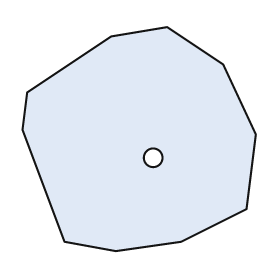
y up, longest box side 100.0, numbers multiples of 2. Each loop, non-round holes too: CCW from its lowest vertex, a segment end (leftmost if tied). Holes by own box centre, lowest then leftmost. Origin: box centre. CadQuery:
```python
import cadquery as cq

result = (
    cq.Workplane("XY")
    .moveTo(-10.0, -48.0)
    .lineTo(18.0, -44.0)
    .lineTo(46.0, -30.0)
    .lineTo(50.0, 2.0)
    .lineTo(36.0, 32.0)
    .lineTo(12.0, 48.0)
    .lineTo(-12.0, 44.0)
    .lineTo(-48.0, 20.0)
    .lineTo(-50.0, 4.0)
    .lineTo(-32.0, -44.0)
    .close()
    .moveTo(6.0, -8.0)
    .circle(4.0)
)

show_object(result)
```